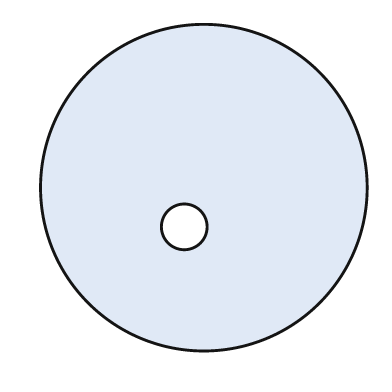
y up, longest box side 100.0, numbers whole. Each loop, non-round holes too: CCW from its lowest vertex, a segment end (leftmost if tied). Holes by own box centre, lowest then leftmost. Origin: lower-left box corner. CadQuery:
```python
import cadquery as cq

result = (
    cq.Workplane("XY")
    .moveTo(50.0, 50.0)
    .circle(50.0)
    .moveTo(44.0, 38.0)
    .circle(7.0)
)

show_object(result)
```